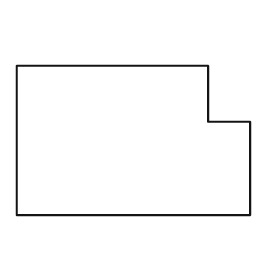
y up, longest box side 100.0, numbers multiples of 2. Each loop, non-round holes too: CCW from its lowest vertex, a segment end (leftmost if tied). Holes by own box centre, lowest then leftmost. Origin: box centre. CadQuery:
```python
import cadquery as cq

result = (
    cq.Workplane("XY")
    .moveTo(-50.0, -32.0)
    .lineTo(50.0, -32.0)
    .lineTo(50.0, 8.0)
    .lineTo(32.0, 8.0)
    .lineTo(32.0, 32.0)
    .lineTo(-50.0, 32.0)
    .close()
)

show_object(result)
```